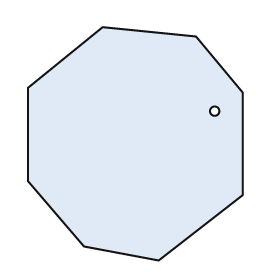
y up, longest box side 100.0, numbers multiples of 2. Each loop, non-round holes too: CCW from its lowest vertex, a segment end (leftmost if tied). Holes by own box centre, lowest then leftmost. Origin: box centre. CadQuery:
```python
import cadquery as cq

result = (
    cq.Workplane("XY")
    .moveTo(10.0, -50.0)
    .lineTo(46.0, -22.0)
    .lineTo(46.0, 22.0)
    .lineTo(26.0, 46.0)
    .lineTo(-14.0, 50.0)
    .lineTo(-46.0, 24.0)
    .lineTo(-46.0, -16.0)
    .lineTo(-22.0, -44.0)
    .close()
    .moveTo(34.0, 14.0)
    .circle(2.0)
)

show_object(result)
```